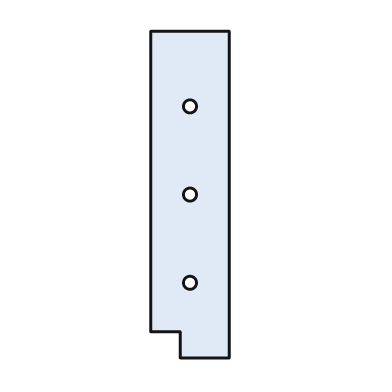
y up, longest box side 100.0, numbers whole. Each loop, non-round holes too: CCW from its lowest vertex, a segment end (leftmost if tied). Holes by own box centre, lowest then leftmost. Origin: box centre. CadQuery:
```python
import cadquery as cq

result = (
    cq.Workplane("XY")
    .moveTo(-3.0, -50.0)
    .lineTo(12.0, -50.0)
    .lineTo(12.0, 50.0)
    .lineTo(-12.0, 50.0)
    .lineTo(-12.0, -42.0)
    .lineTo(-3.0, -42.0)
    .close()
    .moveTo(0.0, -27.0)
    .circle(2.0)
    .moveTo(0.0, 0.0)
    .circle(2.0)
    .moveTo(0.0, 27.0)
    .circle(2.0)
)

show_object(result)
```